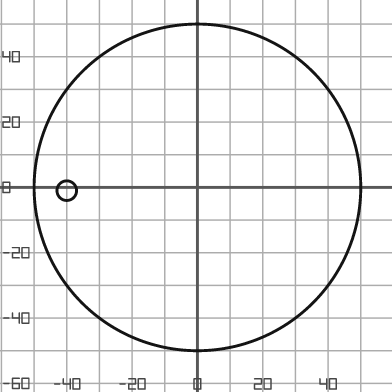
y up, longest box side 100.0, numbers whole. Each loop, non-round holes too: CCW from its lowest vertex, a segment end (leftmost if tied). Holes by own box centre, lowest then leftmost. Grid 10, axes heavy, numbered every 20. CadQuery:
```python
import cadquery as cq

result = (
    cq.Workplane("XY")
    .moveTo(0.0, 0.0)
    .circle(50.0)
    .moveTo(-40.0, -1.0)
    .circle(3.0)
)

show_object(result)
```